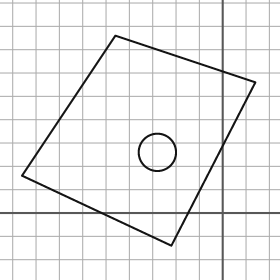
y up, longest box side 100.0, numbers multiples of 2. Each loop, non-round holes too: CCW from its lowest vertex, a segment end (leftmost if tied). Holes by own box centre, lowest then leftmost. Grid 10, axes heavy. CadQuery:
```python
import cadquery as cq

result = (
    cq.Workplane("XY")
    .moveTo(-22.0, -14.0)
    .lineTo(14.0, 56.0)
    .lineTo(-46.0, 76.0)
    .lineTo(-86.0, 16.0)
    .close()
    .moveTo(-28.0, 26.0)
    .circle(8.0)
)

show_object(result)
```